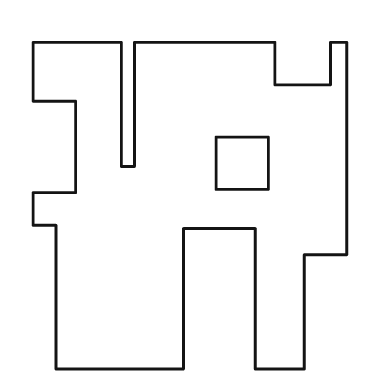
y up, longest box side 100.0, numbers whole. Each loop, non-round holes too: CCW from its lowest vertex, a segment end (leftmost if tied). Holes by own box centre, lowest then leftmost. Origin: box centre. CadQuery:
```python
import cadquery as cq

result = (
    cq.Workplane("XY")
    .moveTo(-41.0, -50.0)
    .lineTo(-2.0, -50.0)
    .lineTo(-2.0, -7.0)
    .lineTo(20.0, -7.0)
    .lineTo(20.0, -50.0)
    .lineTo(35.0, -50.0)
    .lineTo(35.0, -15.0)
    .lineTo(48.0, -15.0)
    .lineTo(48.0, 50.0)
    .lineTo(43.0, 50.0)
    .lineTo(43.0, 37.0)
    .lineTo(26.0, 37.0)
    .lineTo(26.0, 50.0)
    .lineTo(-17.0, 50.0)
    .lineTo(-17.0, 12.0)
    .lineTo(-21.0, 12.0)
    .lineTo(-21.0, 50.0)
    .lineTo(-48.0, 50.0)
    .lineTo(-48.0, 32.0)
    .lineTo(-35.0, 32.0)
    .lineTo(-35.0, 4.0)
    .lineTo(-48.0, 4.0)
    .lineTo(-48.0, -6.0)
    .lineTo(-41.0, -6.0)
    .close()
    .moveTo(8.0, 5.0)
    .lineTo(24.0, 5.0)
    .lineTo(24.0, 21.0)
    .lineTo(8.0, 21.0)
    .close()
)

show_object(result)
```